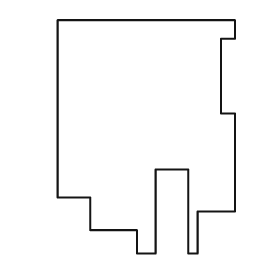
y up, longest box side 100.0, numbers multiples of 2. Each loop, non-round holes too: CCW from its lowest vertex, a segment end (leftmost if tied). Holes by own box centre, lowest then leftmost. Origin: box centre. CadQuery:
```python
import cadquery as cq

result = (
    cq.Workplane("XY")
    .moveTo(-4.0, -50.0)
    .lineTo(4.0, -50.0)
    .lineTo(4.0, -14.0)
    .lineTo(18.0, -14.0)
    .lineTo(18.0, -50.0)
    .lineTo(22.0, -50.0)
    .lineTo(22.0, -32.0)
    .lineTo(38.0, -32.0)
    .lineTo(38.0, 10.0)
    .lineTo(32.0, 10.0)
    .lineTo(32.0, 42.0)
    .lineTo(38.0, 42.0)
    .lineTo(38.0, 50.0)
    .lineTo(-38.0, 50.0)
    .lineTo(-38.0, -26.0)
    .lineTo(-24.0, -26.0)
    .lineTo(-24.0, -40.0)
    .lineTo(-4.0, -40.0)
    .close()
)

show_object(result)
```